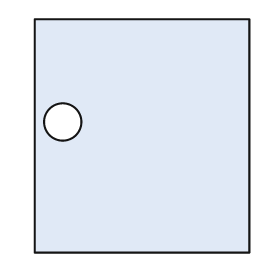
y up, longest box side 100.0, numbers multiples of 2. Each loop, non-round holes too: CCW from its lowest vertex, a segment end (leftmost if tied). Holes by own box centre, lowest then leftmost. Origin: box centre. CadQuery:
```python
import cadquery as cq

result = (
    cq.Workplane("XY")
    .moveTo(-46.0, -50.0)
    .lineTo(46.0, -50.0)
    .lineTo(46.0, 50.0)
    .lineTo(-46.0, 50.0)
    .close()
    .moveTo(-34.0, 6.0)
    .circle(8.0)
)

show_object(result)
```